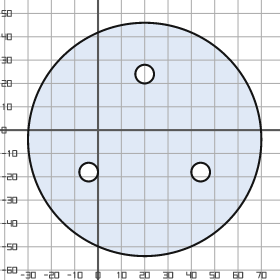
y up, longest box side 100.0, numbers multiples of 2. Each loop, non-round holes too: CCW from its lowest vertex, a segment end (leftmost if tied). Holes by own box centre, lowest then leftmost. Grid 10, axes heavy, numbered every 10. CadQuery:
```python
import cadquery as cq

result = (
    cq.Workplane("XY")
    .moveTo(20.0, -4.0)
    .circle(50.0)
    .moveTo(-4.0, -18.0)
    .circle(4.0)
    .moveTo(44.0, -18.0)
    .circle(4.0)
    .moveTo(20.0, 24.0)
    .circle(4.0)
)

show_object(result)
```